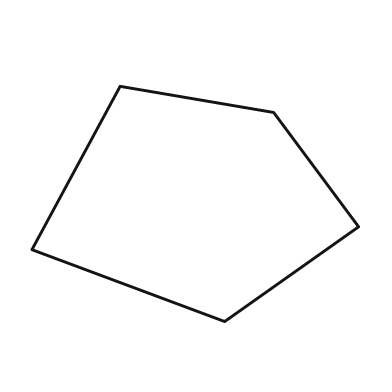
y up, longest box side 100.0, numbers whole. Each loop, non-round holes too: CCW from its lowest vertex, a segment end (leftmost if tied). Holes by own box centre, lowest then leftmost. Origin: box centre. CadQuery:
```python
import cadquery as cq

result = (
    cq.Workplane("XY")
    .moveTo(9.0, -36.0)
    .lineTo(50.0, -7.0)
    .lineTo(24.0, 28.0)
    .lineTo(-23.0, 36.0)
    .lineTo(-50.0, -14.0)
    .close()
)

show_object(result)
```